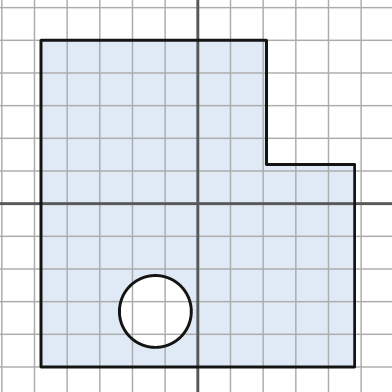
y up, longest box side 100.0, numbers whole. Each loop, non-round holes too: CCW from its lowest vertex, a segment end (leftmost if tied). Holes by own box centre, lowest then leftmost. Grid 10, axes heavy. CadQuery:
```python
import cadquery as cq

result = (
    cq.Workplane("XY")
    .moveTo(-48.0, -50.0)
    .lineTo(48.0, -50.0)
    .lineTo(48.0, 12.0)
    .lineTo(21.0, 12.0)
    .lineTo(21.0, 50.0)
    .lineTo(-48.0, 50.0)
    .close()
    .moveTo(-13.0, -33.0)
    .circle(11.0)
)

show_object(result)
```